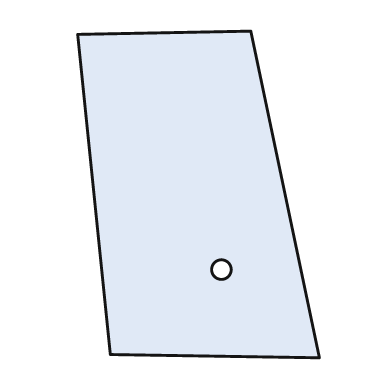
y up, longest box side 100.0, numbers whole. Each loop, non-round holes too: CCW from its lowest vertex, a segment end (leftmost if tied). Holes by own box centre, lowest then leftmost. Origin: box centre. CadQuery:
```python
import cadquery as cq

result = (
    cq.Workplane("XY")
    .moveTo(37.0, -50.0)
    .lineTo(16.0, 50.0)
    .lineTo(-37.0, 49.0)
    .lineTo(-27.0, -49.0)
    .close()
    .moveTo(7.0, -23.0)
    .circle(3.0)
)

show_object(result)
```